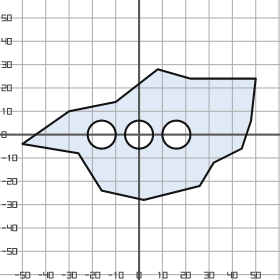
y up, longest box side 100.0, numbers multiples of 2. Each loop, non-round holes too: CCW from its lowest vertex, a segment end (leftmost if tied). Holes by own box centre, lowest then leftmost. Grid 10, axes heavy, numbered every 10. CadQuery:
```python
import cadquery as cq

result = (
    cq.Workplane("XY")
    .moveTo(2.0, -28.0)
    .lineTo(26.0, -22.0)
    .lineTo(32.0, -12.0)
    .lineTo(44.0, -6.0)
    .lineTo(48.0, 6.0)
    .lineTo(50.0, 24.0)
    .lineTo(22.0, 24.0)
    .lineTo(8.0, 28.0)
    .lineTo(-10.0, 14.0)
    .lineTo(-30.0, 10.0)
    .lineTo(-50.0, -4.0)
    .lineTo(-26.0, -8.0)
    .lineTo(-16.0, -24.0)
    .close()
    .moveTo(-16.0, 0.0)
    .circle(6.0)
    .moveTo(0.0, 0.0)
    .circle(6.0)
    .moveTo(16.0, 0.0)
    .circle(6.0)
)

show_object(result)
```